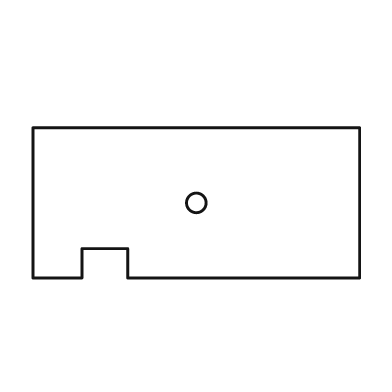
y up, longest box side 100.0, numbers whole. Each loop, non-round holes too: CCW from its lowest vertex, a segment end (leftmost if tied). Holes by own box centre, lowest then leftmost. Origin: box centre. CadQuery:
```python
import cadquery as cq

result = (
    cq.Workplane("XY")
    .moveTo(-50.0, -23.0)
    .lineTo(-35.0, -23.0)
    .lineTo(-35.0, -14.0)
    .lineTo(-21.0, -14.0)
    .lineTo(-21.0, -23.0)
    .lineTo(50.0, -23.0)
    .lineTo(50.0, 23.0)
    .lineTo(-50.0, 23.0)
    .close()
    .moveTo(0.0, 0.0)
    .circle(3.0)
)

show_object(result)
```